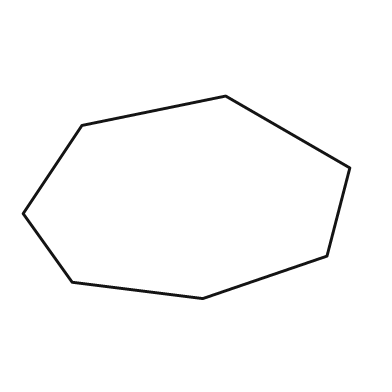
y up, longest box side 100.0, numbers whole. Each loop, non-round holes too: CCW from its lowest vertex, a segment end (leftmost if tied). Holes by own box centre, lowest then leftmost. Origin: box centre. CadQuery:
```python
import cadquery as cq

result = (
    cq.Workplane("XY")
    .moveTo(5.0, -31.0)
    .lineTo(43.0, -18.0)
    .lineTo(50.0, 9.0)
    .lineTo(12.0, 31.0)
    .lineTo(-32.0, 22.0)
    .lineTo(-50.0, -5.0)
    .lineTo(-35.0, -26.0)
    .close()
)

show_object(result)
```